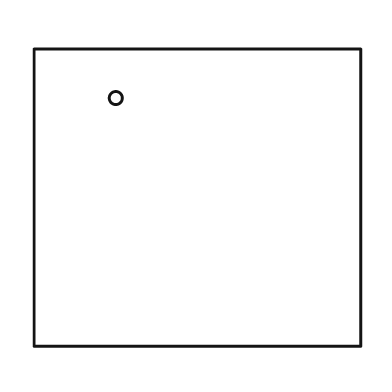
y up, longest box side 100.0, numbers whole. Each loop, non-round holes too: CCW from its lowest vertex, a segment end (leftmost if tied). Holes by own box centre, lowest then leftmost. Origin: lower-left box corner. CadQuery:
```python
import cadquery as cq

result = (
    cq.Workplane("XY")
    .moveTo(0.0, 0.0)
    .lineTo(100.0, 0.0)
    .lineTo(100.0, 91.0)
    .lineTo(0.0, 91.0)
    .close()
    .moveTo(25.0, 76.0)
    .circle(2.0)
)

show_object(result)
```